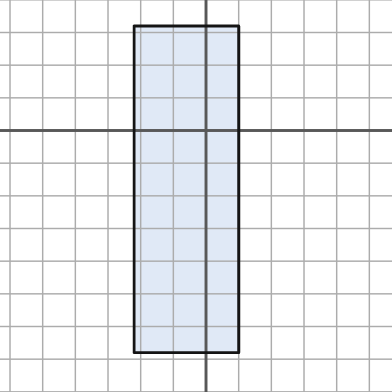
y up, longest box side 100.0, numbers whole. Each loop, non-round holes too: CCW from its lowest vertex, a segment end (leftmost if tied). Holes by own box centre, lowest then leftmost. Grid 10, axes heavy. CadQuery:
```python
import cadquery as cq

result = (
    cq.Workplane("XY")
    .moveTo(-22.0, -68.0)
    .lineTo(10.0, -68.0)
    .lineTo(10.0, 32.0)
    .lineTo(-22.0, 32.0)
    .close()
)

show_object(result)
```